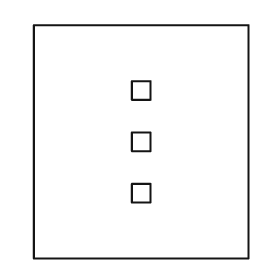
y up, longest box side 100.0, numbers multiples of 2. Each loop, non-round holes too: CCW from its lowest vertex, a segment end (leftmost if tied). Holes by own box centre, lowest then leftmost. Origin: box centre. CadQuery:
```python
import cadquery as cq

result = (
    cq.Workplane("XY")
    .moveTo(-46.0, -50.0)
    .lineTo(46.0, -50.0)
    .lineTo(46.0, 50.0)
    .lineTo(-46.0, 50.0)
    .close()
    .moveTo(-4.0, -26.0)
    .lineTo(4.0, -26.0)
    .lineTo(4.0, -18.0)
    .lineTo(-4.0, -18.0)
    .close()
    .moveTo(-4.0, -4.0)
    .lineTo(4.0, -4.0)
    .lineTo(4.0, 4.0)
    .lineTo(-4.0, 4.0)
    .close()
    .moveTo(-4.0, 18.0)
    .lineTo(4.0, 18.0)
    .lineTo(4.0, 26.0)
    .lineTo(-4.0, 26.0)
    .close()
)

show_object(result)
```